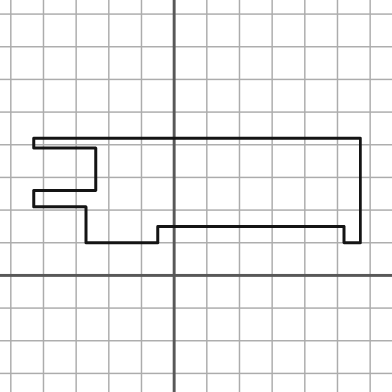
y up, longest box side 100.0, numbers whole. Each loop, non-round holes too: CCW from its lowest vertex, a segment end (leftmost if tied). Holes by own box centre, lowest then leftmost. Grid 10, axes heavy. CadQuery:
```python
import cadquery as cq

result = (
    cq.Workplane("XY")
    .moveTo(-27.0, 10.0)
    .lineTo(-5.0, 10.0)
    .lineTo(-5.0, 15.0)
    .lineTo(52.0, 15.0)
    .lineTo(52.0, 10.0)
    .lineTo(57.0, 10.0)
    .lineTo(57.0, 42.0)
    .lineTo(-43.0, 42.0)
    .lineTo(-43.0, 39.0)
    .lineTo(-24.0, 39.0)
    .lineTo(-24.0, 26.0)
    .lineTo(-43.0, 26.0)
    .lineTo(-43.0, 21.0)
    .lineTo(-27.0, 21.0)
    .close()
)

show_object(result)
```